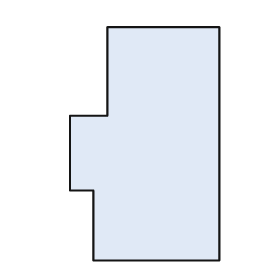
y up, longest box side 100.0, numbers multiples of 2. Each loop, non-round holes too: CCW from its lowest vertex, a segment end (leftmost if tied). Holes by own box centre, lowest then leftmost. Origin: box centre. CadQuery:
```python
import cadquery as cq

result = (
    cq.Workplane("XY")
    .moveTo(-22.0, -50.0)
    .lineTo(32.0, -50.0)
    .lineTo(32.0, 50.0)
    .lineTo(-16.0, 50.0)
    .lineTo(-16.0, 12.0)
    .lineTo(-32.0, 12.0)
    .lineTo(-32.0, -20.0)
    .lineTo(-22.0, -20.0)
    .close()
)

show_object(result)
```